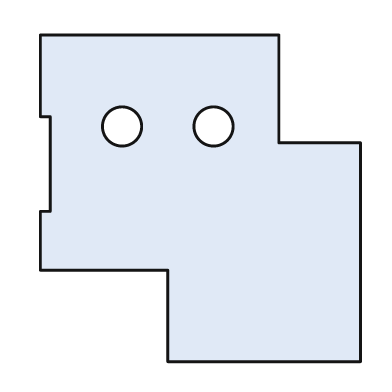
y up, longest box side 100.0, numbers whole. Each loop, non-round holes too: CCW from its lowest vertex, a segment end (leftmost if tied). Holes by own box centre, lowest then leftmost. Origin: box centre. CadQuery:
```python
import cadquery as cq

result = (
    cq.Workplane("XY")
    .moveTo(-10.0, -50.0)
    .lineTo(49.0, -50.0)
    .lineTo(49.0, 17.0)
    .lineTo(24.0, 17.0)
    .lineTo(24.0, 50.0)
    .lineTo(-49.0, 50.0)
    .lineTo(-49.0, 25.0)
    .lineTo(-46.0, 25.0)
    .lineTo(-46.0, -4.0)
    .lineTo(-49.0, -4.0)
    .lineTo(-49.0, -22.0)
    .lineTo(-10.0, -22.0)
    .close()
    .moveTo(-24.0, 22.0)
    .circle(6.0)
    .moveTo(4.0, 22.0)
    .circle(6.0)
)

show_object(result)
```